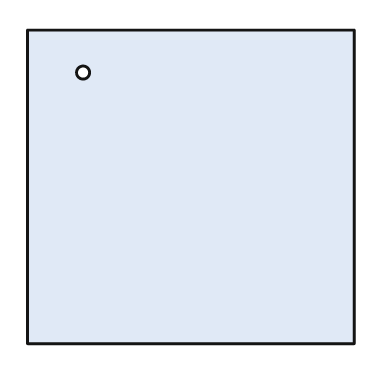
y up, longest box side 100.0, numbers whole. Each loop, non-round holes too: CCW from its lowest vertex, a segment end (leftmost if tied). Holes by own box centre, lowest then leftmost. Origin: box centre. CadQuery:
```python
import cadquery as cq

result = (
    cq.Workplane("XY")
    .moveTo(-50.0, -48.0)
    .lineTo(50.0, -48.0)
    .lineTo(50.0, 48.0)
    .lineTo(-50.0, 48.0)
    .close()
    .moveTo(-33.0, 35.0)
    .circle(2.0)
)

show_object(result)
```